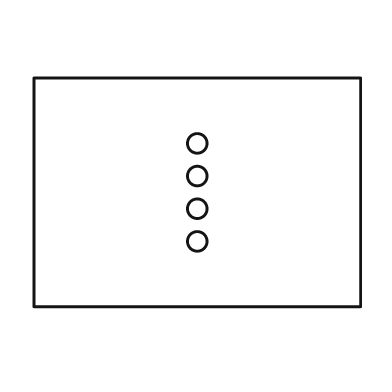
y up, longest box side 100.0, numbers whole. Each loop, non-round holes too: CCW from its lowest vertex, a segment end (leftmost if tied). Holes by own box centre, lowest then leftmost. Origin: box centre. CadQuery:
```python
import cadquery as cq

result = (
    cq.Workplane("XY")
    .moveTo(-50.0, -35.0)
    .lineTo(50.0, -35.0)
    .lineTo(50.0, 35.0)
    .lineTo(-50.0, 35.0)
    .close()
    .moveTo(0.0, -15.0)
    .circle(3.0)
    .moveTo(0.0, -5.0)
    .circle(3.0)
    .moveTo(0.0, 5.0)
    .circle(3.0)
    .moveTo(0.0, 15.0)
    .circle(3.0)
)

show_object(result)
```